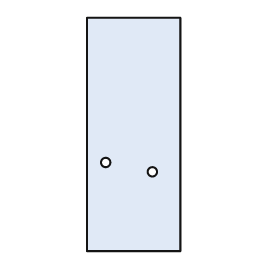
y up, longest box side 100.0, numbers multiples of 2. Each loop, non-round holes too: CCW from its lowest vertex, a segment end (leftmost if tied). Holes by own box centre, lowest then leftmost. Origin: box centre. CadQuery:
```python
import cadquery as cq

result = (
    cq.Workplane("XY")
    .moveTo(-20.0, -50.0)
    .lineTo(20.0, -50.0)
    .lineTo(20.0, 50.0)
    .lineTo(-20.0, 50.0)
    .close()
    .moveTo(8.0, -16.0)
    .circle(2.0)
    .moveTo(-12.0, -12.0)
    .circle(2.0)
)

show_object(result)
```